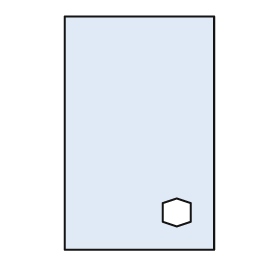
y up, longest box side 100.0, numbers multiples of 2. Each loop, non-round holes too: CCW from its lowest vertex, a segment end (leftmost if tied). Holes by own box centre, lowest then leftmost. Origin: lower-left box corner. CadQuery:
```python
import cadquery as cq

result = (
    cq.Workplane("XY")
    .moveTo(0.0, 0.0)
    .lineTo(64.0, 0.0)
    .lineTo(64.0, 100.0)
    .lineTo(0.0, 100.0)
    .close()
    .moveTo(48.0, 10.0)
    .lineTo(54.0, 12.0)
    .lineTo(54.0, 20.0)
    .lineTo(48.0, 22.0)
    .lineTo(42.0, 20.0)
    .lineTo(42.0, 12.0)
    .close()
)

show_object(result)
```